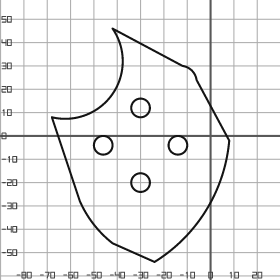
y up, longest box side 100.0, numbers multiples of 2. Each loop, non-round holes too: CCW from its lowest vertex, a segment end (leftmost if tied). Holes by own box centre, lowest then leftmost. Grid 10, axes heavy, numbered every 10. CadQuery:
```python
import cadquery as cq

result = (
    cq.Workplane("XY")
    .moveTo(-24.0, -54.0)
    .threePointArc((-2.0, -32.0), (8.0, -2.0))
    .lineTo(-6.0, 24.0)
    .threePointArc((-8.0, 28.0), (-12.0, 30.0))
    .lineTo(-42.0, 46.0)
    .threePointArc((-42.0, 18.0), (-68.0, 8.0))
    .lineTo(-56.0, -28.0)
    .threePointArc((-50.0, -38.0), (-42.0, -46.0))
    .close()
    .moveTo(-30.0, -20.0)
    .circle(4.0)
    .moveTo(-46.0, -4.0)
    .circle(4.0)
    .moveTo(-14.0, -4.0)
    .circle(4.0)
    .moveTo(-30.0, 12.0)
    .circle(4.0)
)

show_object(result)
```